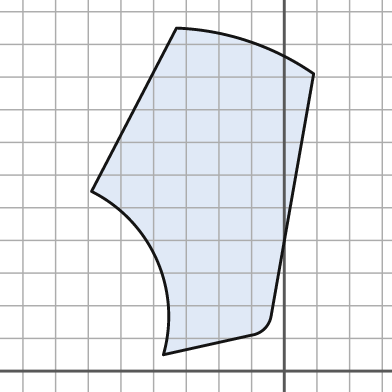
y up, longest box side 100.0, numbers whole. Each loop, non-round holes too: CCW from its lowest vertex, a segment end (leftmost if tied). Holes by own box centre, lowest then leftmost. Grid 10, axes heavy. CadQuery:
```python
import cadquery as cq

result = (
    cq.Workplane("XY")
    .moveTo(-37.0, 5.0)
    .lineTo(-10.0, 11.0)
    .threePointArc((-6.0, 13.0), (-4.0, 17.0))
    .lineTo(9.0, 91.0)
    .threePointArc((-11.0, 101.0), (-33.0, 105.0))
    .lineTo(-59.0, 55.0)
    .threePointArc((-39.0, 34.0), (-37.0, 5.0))
    .close()
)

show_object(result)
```